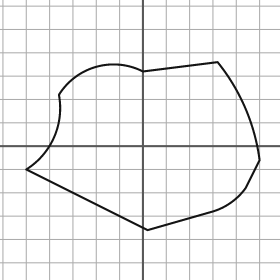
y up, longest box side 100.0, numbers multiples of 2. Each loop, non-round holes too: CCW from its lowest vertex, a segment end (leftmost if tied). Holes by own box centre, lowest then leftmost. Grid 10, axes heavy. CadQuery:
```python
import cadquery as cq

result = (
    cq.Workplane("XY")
    .moveTo(2.0, -36.0)
    .lineTo(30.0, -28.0)
    .threePointArc((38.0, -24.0), (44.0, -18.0))
    .lineTo(50.0, -6.0)
    .threePointArc((44.0, 16.0), (32.0, 36.0))
    .lineTo(0.0, 32.0)
    .threePointArc((-20.0, 34.0), (-36.0, 22.0))
    .threePointArc((-38.0, 4.0), (-50.0, -10.0))
    .close()
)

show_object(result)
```